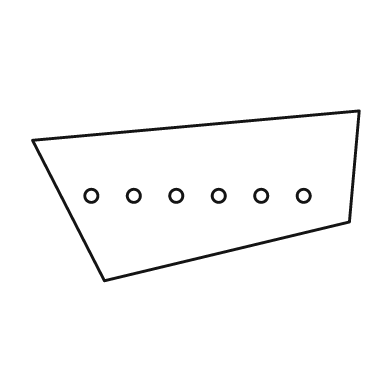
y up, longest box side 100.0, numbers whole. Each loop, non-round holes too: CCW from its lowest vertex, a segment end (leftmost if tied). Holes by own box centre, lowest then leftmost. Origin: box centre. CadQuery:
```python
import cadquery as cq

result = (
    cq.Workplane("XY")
    .moveTo(-28.0, -26.0)
    .lineTo(47.0, -8.0)
    .lineTo(50.0, 26.0)
    .lineTo(-50.0, 17.0)
    .close()
    .moveTo(-32.0, 0.0)
    .circle(2.0)
    .moveTo(-19.0, 0.0)
    .circle(2.0)
    .moveTo(-6.0, 0.0)
    .circle(2.0)
    .moveTo(7.0, 0.0)
    .circle(2.0)
    .moveTo(20.0, 0.0)
    .circle(2.0)
    .moveTo(33.0, 0.0)
    .circle(2.0)
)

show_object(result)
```